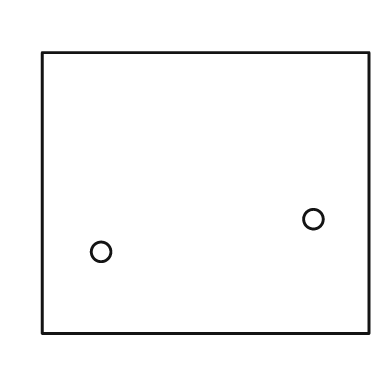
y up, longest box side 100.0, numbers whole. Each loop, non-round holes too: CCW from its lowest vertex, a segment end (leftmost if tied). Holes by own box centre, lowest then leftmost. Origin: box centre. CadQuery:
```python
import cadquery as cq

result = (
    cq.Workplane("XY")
    .moveTo(-50.0, -43.0)
    .lineTo(50.0, -43.0)
    .lineTo(50.0, 43.0)
    .lineTo(-50.0, 43.0)
    .close()
    .moveTo(-32.0, -18.0)
    .circle(3.0)
    .moveTo(33.0, -8.0)
    .circle(3.0)
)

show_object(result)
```